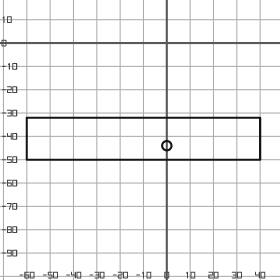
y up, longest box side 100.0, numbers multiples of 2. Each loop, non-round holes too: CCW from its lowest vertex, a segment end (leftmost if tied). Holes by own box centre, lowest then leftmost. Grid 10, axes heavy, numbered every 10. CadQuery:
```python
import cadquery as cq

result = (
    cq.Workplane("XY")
    .moveTo(-60.0, -50.0)
    .lineTo(40.0, -50.0)
    .lineTo(40.0, -32.0)
    .lineTo(-60.0, -32.0)
    .close()
    .moveTo(0.0, -44.0)
    .circle(2.0)
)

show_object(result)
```